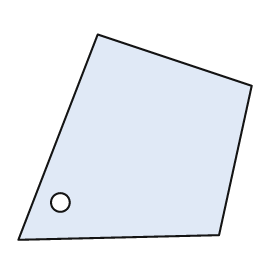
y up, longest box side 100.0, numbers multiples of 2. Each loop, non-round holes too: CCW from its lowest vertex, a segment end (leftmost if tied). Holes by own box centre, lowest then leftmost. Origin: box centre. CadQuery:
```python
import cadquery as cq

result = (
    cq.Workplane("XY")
    .moveTo(-50.0, -44.0)
    .lineTo(36.0, -42.0)
    .lineTo(50.0, 22.0)
    .lineTo(-16.0, 44.0)
    .close()
    .moveTo(-32.0, -28.0)
    .circle(4.0)
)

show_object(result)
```